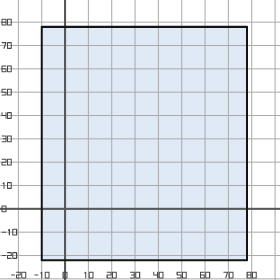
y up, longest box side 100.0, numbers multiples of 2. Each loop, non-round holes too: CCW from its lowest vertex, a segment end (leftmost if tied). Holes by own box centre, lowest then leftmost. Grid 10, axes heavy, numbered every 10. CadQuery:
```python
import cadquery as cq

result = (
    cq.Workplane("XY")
    .moveTo(-10.0, -22.0)
    .lineTo(78.0, -22.0)
    .lineTo(78.0, 78.0)
    .lineTo(-10.0, 78.0)
    .close()
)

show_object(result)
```